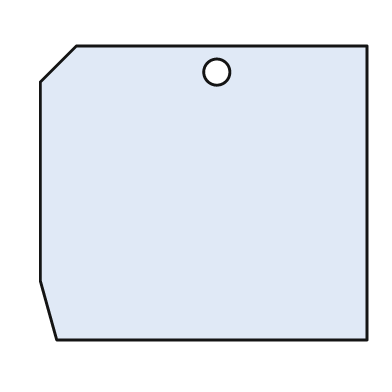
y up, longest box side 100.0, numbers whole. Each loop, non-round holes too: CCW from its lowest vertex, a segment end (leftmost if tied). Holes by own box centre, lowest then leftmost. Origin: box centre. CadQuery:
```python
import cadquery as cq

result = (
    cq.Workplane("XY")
    .moveTo(-45.0, -45.0)
    .lineTo(50.0, -45.0)
    .lineTo(50.0, 45.0)
    .lineTo(-39.0, 45.0)
    .lineTo(-50.0, 34.0)
    .lineTo(-50.0, -27.0)
    .close()
    .moveTo(4.0, 37.0)
    .circle(4.0)
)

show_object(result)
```